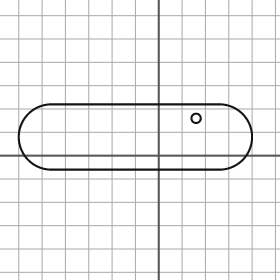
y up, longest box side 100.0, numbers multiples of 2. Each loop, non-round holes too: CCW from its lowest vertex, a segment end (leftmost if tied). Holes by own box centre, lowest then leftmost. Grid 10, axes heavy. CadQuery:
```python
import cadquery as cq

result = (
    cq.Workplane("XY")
    .moveTo(-46.0, -6.0)
    .lineTo(26.0, -6.0)
    .threePointArc((40.0, 8.0), (26.0, 22.0))
    .lineTo(-46.0, 22.0)
    .threePointArc((-60.0, 8.0), (-46.0, -6.0))
    .close()
    .moveTo(16.0, 16.0)
    .circle(2.0)
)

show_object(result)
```